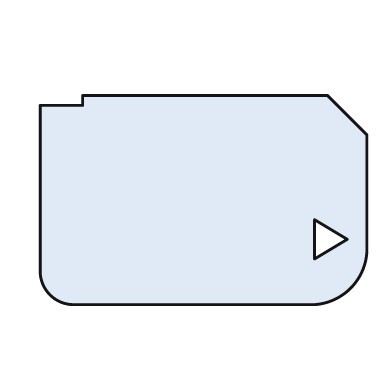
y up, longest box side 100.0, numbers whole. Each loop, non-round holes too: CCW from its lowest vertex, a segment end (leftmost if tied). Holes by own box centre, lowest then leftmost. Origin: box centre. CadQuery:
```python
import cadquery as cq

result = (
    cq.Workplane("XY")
    .moveTo(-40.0, -32.0)
    .lineTo(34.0, -32.0)
    .threePointArc((45.0, -27.0), (50.0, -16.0))
    .lineTo(50.0, 20.0)
    .lineTo(38.0, 32.0)
    .lineTo(-37.0, 32.0)
    .lineTo(-37.0, 29.0)
    .lineTo(-50.0, 29.0)
    .lineTo(-50.0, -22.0)
    .threePointArc((-47.0, -29.0), (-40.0, -32.0))
    .close()
    .moveTo(34.0, -18.0)
    .lineTo(44.0, -12.0)
    .lineTo(34.0, -6.0)
    .close()
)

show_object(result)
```